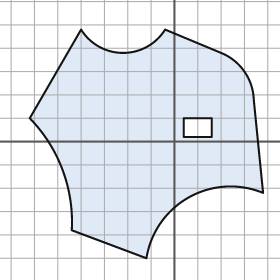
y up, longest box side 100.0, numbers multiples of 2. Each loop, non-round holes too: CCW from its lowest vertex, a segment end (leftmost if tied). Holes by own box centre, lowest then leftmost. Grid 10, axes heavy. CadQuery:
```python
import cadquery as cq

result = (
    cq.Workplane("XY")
    .moveTo(-12.0, -50.0)
    .threePointArc((6.0, -24.0), (38.0, -22.0))
    .lineTo(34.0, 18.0)
    .threePointArc((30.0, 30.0), (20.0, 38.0))
    .lineTo(-4.0, 48.0)
    .threePointArc((-22.0, 38.0), (-40.0, 48.0))
    .lineTo(-62.0, 10.0)
    .threePointArc((-48.0, -12.0), (-44.0, -38.0))
    .close()
    .moveTo(4.0, 2.0)
    .lineTo(16.0, 2.0)
    .lineTo(16.0, 10.0)
    .lineTo(4.0, 10.0)
    .close()
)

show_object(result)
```